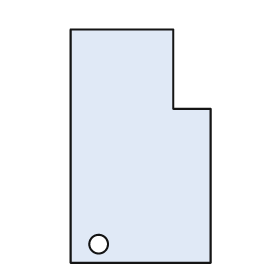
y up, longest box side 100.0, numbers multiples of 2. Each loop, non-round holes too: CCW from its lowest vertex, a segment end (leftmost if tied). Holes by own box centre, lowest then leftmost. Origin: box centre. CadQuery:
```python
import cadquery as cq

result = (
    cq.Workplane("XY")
    .moveTo(-30.0, -50.0)
    .lineTo(30.0, -50.0)
    .lineTo(30.0, 16.0)
    .lineTo(14.0, 16.0)
    .lineTo(14.0, 50.0)
    .lineTo(-30.0, 50.0)
    .close()
    .moveTo(-18.0, -42.0)
    .circle(4.0)
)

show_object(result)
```